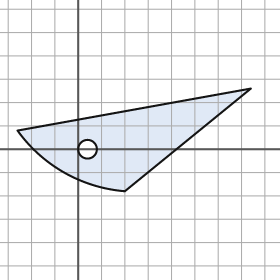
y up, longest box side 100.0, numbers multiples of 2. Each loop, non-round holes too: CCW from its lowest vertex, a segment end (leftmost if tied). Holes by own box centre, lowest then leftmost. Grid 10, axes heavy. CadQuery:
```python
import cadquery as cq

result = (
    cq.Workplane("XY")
    .moveTo(20.0, -18.0)
    .lineTo(74.0, 26.0)
    .lineTo(-26.0, 8.0)
    .threePointArc((-6.0, -10.0), (20.0, -18.0))
    .close()
    .moveTo(4.0, 0.0)
    .circle(4.0)
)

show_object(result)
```